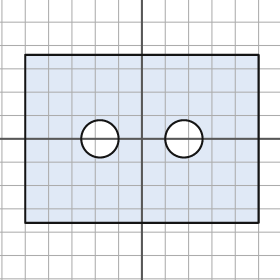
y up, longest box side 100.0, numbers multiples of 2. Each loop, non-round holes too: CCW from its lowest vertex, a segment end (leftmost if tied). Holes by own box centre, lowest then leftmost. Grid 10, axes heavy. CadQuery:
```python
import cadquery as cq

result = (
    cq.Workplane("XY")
    .moveTo(-50.0, -36.0)
    .lineTo(50.0, -36.0)
    .lineTo(50.0, 36.0)
    .lineTo(-50.0, 36.0)
    .close()
    .moveTo(-18.0, 0.0)
    .circle(8.0)
    .moveTo(18.0, 0.0)
    .circle(8.0)
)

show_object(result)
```